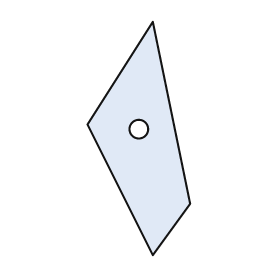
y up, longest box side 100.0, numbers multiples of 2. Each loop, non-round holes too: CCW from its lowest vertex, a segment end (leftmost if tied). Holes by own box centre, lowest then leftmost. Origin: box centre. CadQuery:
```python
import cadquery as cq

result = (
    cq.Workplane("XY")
    .moveTo(6.0, -50.0)
    .lineTo(22.0, -28.0)
    .lineTo(6.0, 50.0)
    .lineTo(-22.0, 6.0)
    .close()
    .moveTo(0.0, 4.0)
    .circle(4.0)
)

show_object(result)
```